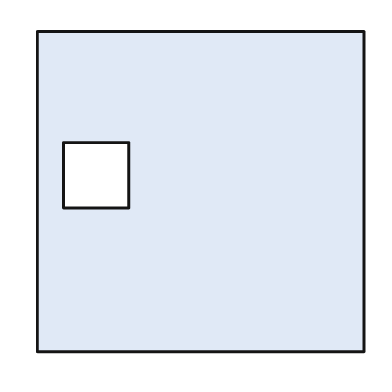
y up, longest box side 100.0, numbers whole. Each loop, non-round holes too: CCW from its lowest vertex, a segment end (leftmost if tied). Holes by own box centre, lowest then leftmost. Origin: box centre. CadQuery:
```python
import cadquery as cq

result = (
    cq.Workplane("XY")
    .moveTo(-50.0, -49.0)
    .lineTo(50.0, -49.0)
    .lineTo(50.0, 49.0)
    .lineTo(-50.0, 49.0)
    .close()
    .moveTo(-42.0, -5.0)
    .lineTo(-22.0, -5.0)
    .lineTo(-22.0, 15.0)
    .lineTo(-42.0, 15.0)
    .close()
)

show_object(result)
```